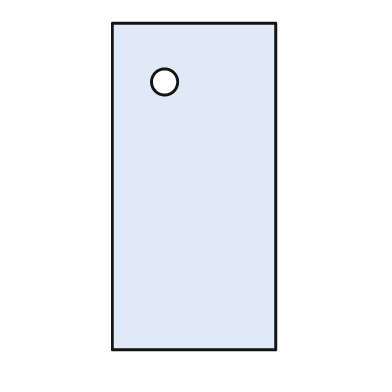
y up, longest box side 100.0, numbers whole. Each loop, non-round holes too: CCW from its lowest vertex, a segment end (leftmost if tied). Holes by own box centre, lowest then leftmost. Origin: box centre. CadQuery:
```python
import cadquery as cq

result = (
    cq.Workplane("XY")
    .moveTo(-25.0, -50.0)
    .lineTo(25.0, -50.0)
    .lineTo(25.0, 50.0)
    .lineTo(-25.0, 50.0)
    .close()
    .moveTo(-9.0, 32.0)
    .circle(4.0)
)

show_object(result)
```